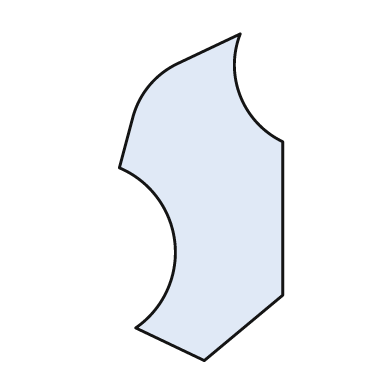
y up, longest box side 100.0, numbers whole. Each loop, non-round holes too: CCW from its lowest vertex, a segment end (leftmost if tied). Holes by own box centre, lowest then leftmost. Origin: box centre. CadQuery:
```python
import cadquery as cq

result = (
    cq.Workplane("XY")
    .moveTo(1.0, -50.0)
    .lineTo(25.0, -30.0)
    .lineTo(25.0, 17.0)
    .threePointArc((12.0, 31.0), (12.0, 50.0))
    .lineTo(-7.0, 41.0)
    .threePointArc((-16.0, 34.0), (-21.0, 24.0))
    .lineTo(-25.0, 9.0)
    .threePointArc((-8.0, -14.0), (-20.0, -40.0))
    .close()
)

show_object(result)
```